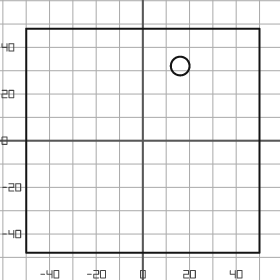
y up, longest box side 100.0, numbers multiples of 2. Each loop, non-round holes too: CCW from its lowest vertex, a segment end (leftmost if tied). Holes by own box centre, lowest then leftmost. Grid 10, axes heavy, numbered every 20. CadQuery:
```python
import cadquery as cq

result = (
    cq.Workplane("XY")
    .moveTo(-50.0, -48.0)
    .lineTo(50.0, -48.0)
    .lineTo(50.0, 48.0)
    .lineTo(-50.0, 48.0)
    .close()
    .moveTo(16.0, 32.0)
    .circle(4.0)
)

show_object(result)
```